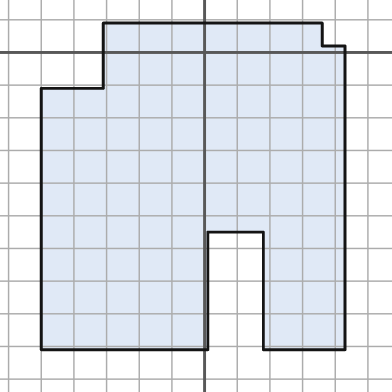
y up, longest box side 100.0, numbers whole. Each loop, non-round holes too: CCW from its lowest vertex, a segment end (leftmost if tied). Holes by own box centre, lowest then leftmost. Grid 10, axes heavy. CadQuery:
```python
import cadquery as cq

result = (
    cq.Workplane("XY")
    .moveTo(-50.0, -91.0)
    .lineTo(1.0, -91.0)
    .lineTo(1.0, -55.0)
    .lineTo(18.0, -55.0)
    .lineTo(18.0, -91.0)
    .lineTo(43.0, -91.0)
    .lineTo(43.0, 2.0)
    .lineTo(36.0, 2.0)
    .lineTo(36.0, 9.0)
    .lineTo(-31.0, 9.0)
    .lineTo(-31.0, -11.0)
    .lineTo(-50.0, -11.0)
    .close()
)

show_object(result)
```